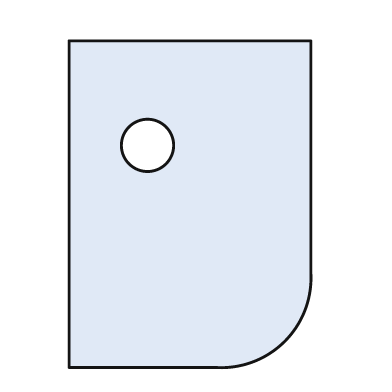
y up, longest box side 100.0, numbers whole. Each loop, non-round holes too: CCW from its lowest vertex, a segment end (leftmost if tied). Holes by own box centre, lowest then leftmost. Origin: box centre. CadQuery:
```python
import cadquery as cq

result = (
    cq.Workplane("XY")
    .moveTo(-37.0, -50.0)
    .lineTo(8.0, -50.0)
    .threePointArc((29.0, -42.0), (37.0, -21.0))
    .lineTo(37.0, 50.0)
    .lineTo(-37.0, 50.0)
    .close()
    .moveTo(-13.0, 18.0)
    .circle(8.0)
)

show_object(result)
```